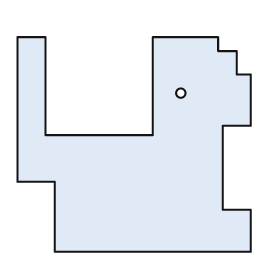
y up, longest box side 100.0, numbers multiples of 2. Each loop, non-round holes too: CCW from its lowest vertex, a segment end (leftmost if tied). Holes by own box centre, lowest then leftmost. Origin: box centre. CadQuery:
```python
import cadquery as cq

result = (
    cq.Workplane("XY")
    .moveTo(-34.0, -46.0)
    .lineTo(50.0, -46.0)
    .lineTo(50.0, -28.0)
    .lineTo(38.0, -28.0)
    .lineTo(38.0, 8.0)
    .lineTo(50.0, 8.0)
    .lineTo(50.0, 30.0)
    .lineTo(44.0, 30.0)
    .lineTo(44.0, 40.0)
    .lineTo(36.0, 40.0)
    .lineTo(36.0, 46.0)
    .lineTo(8.0, 46.0)
    .lineTo(8.0, 4.0)
    .lineTo(-38.0, 4.0)
    .lineTo(-38.0, 46.0)
    .lineTo(-50.0, 46.0)
    .lineTo(-50.0, -16.0)
    .lineTo(-34.0, -16.0)
    .close()
    .moveTo(20.0, 22.0)
    .circle(2.0)
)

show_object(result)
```